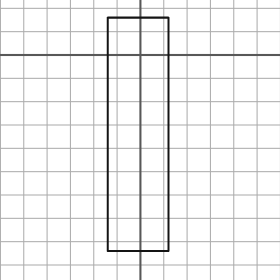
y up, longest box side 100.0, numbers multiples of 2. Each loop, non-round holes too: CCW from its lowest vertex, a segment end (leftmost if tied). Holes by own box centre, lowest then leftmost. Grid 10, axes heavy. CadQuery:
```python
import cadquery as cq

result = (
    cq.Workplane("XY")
    .moveTo(-14.0, -84.0)
    .lineTo(12.0, -84.0)
    .lineTo(12.0, 16.0)
    .lineTo(-14.0, 16.0)
    .close()
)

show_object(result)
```